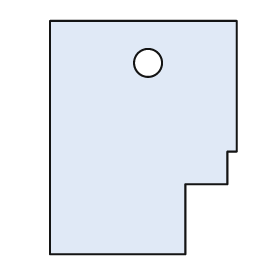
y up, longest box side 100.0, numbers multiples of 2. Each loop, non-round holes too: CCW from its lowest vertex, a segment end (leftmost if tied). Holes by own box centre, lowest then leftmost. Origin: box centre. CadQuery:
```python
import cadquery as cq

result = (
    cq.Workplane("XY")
    .moveTo(-40.0, -50.0)
    .lineTo(18.0, -50.0)
    .lineTo(18.0, -20.0)
    .lineTo(36.0, -20.0)
    .lineTo(36.0, -6.0)
    .lineTo(40.0, -6.0)
    .lineTo(40.0, 50.0)
    .lineTo(-40.0, 50.0)
    .close()
    .moveTo(2.0, 32.0)
    .circle(6.0)
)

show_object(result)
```